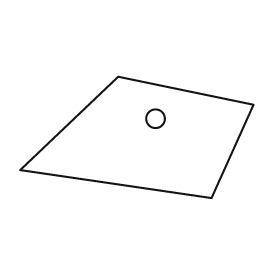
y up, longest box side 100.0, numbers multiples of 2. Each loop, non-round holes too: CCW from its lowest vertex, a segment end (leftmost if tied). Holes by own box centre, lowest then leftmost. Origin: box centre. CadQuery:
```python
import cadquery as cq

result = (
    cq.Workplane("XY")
    .moveTo(32.0, -26.0)
    .lineTo(50.0, 14.0)
    .lineTo(-8.0, 26.0)
    .lineTo(-50.0, -14.0)
    .close()
    .moveTo(8.0, 8.0)
    .circle(4.0)
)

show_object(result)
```